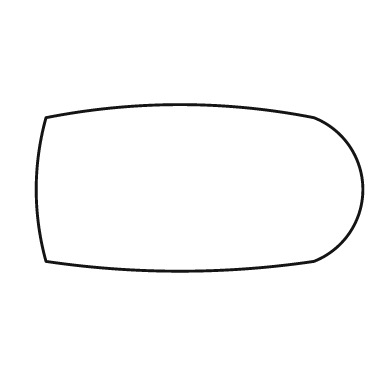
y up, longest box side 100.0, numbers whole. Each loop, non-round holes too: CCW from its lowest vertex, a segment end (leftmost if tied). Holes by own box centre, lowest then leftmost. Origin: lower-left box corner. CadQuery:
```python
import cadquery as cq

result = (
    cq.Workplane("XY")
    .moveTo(3.0, 3.0)
    .threePointArc((44.0, 0.0), (85.0, 3.0))
    .threePointArc((100.0, 25.0), (85.0, 47.0))
    .threePointArc((44.0, 51.0), (3.0, 47.0))
    .threePointArc((0.0, 25.0), (3.0, 3.0))
    .close()
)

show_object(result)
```